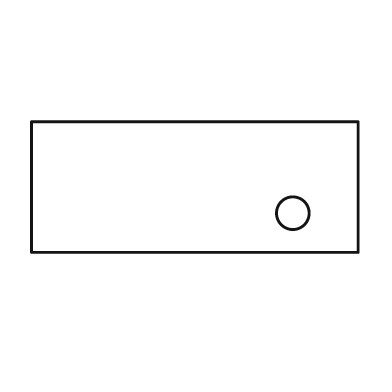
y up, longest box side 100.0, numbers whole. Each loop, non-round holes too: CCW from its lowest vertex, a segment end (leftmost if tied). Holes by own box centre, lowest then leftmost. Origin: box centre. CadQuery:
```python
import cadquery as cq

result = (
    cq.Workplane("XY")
    .moveTo(-50.0, -20.0)
    .lineTo(50.0, -20.0)
    .lineTo(50.0, 20.0)
    .lineTo(-50.0, 20.0)
    .close()
    .moveTo(30.0, -8.0)
    .circle(5.0)
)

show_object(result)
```